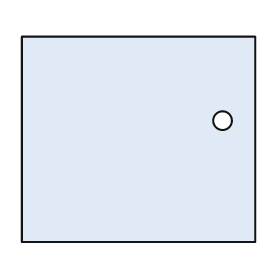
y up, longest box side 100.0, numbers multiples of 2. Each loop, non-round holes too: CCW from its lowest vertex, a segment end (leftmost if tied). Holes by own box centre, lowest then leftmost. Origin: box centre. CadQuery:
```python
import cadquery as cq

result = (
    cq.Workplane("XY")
    .moveTo(-50.0, -44.0)
    .lineTo(50.0, -44.0)
    .lineTo(50.0, 44.0)
    .lineTo(-50.0, 44.0)
    .close()
    .moveTo(36.0, 8.0)
    .circle(4.0)
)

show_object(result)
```